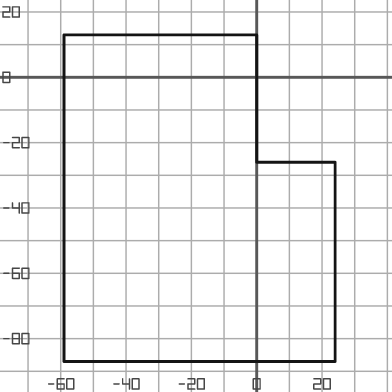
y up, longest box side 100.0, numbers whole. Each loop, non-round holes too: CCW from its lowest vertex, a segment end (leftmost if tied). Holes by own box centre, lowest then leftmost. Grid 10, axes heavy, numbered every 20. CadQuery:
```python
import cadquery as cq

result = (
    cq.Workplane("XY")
    .moveTo(-59.0, -87.0)
    .lineTo(24.0, -87.0)
    .lineTo(24.0, -26.0)
    .lineTo(0.0, -26.0)
    .lineTo(0.0, 13.0)
    .lineTo(-59.0, 13.0)
    .close()
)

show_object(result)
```